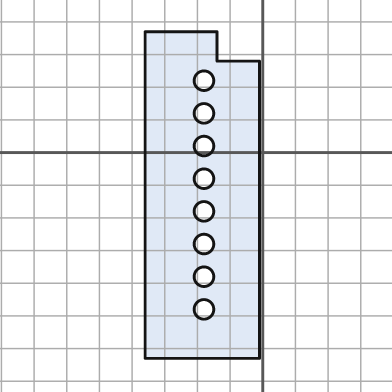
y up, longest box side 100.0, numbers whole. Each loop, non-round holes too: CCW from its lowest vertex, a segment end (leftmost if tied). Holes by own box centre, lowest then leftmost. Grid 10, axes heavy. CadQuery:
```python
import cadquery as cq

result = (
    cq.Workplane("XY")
    .moveTo(-36.0, -63.0)
    .lineTo(-1.0, -63.0)
    .lineTo(-1.0, 28.0)
    .lineTo(-14.0, 28.0)
    .lineTo(-14.0, 37.0)
    .lineTo(-36.0, 37.0)
    .close()
    .moveTo(-18.0, -48.0)
    .circle(3.0)
    .moveTo(-18.0, -38.0)
    .circle(3.0)
    .moveTo(-18.0, -28.0)
    .circle(3.0)
    .moveTo(-18.0, -18.0)
    .circle(3.0)
    .moveTo(-18.0, -8.0)
    .circle(3.0)
    .moveTo(-18.0, 2.0)
    .circle(3.0)
    .moveTo(-18.0, 12.0)
    .circle(3.0)
    .moveTo(-18.0, 22.0)
    .circle(3.0)
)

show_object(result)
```